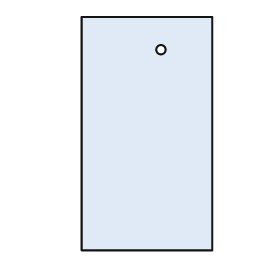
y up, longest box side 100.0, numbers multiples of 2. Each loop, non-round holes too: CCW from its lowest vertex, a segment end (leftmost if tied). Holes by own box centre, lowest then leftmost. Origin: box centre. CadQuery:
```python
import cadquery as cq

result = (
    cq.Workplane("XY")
    .moveTo(-28.0, -50.0)
    .lineTo(28.0, -50.0)
    .lineTo(28.0, 50.0)
    .lineTo(-28.0, 50.0)
    .close()
    .moveTo(6.0, 36.0)
    .circle(2.0)
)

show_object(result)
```